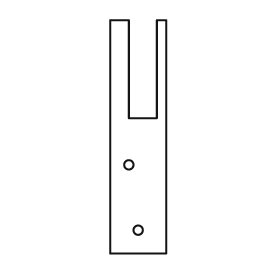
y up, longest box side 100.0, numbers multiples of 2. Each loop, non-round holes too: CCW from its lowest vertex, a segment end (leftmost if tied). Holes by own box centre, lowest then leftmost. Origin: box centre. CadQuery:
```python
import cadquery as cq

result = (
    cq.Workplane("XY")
    .moveTo(-12.0, -50.0)
    .lineTo(12.0, -50.0)
    .lineTo(12.0, 50.0)
    .lineTo(8.0, 50.0)
    .lineTo(8.0, 8.0)
    .lineTo(-4.0, 8.0)
    .lineTo(-4.0, 50.0)
    .lineTo(-12.0, 50.0)
    .close()
    .moveTo(0.0, -40.0)
    .circle(2.0)
    .moveTo(-4.0, -12.0)
    .circle(2.0)
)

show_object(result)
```